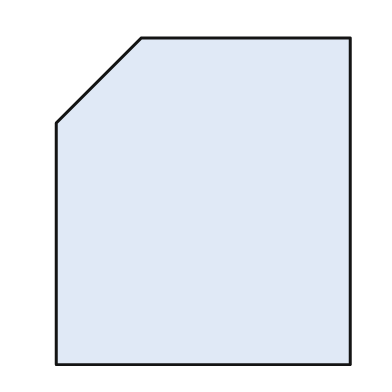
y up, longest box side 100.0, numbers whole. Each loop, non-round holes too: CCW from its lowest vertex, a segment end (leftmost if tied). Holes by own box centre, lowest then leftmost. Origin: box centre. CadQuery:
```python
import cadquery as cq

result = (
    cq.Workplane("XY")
    .moveTo(-45.0, -50.0)
    .lineTo(45.0, -50.0)
    .lineTo(45.0, 50.0)
    .lineTo(-19.0, 50.0)
    .lineTo(-45.0, 24.0)
    .close()
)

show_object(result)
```